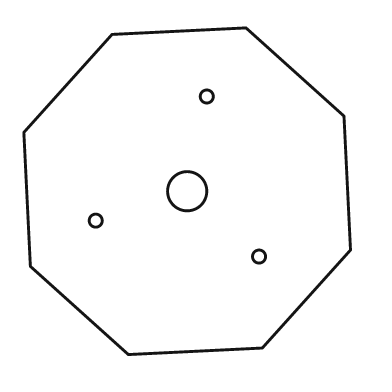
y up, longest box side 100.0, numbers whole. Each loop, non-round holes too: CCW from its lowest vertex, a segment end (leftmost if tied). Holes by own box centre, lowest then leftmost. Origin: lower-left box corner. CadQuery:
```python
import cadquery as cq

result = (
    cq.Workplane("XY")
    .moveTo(32.0, 0.0)
    .lineTo(73.0, 2.0)
    .lineTo(100.0, 32.0)
    .lineTo(98.0, 73.0)
    .lineTo(68.0, 100.0)
    .lineTo(27.0, 98.0)
    .lineTo(0.0, 68.0)
    .lineTo(2.0, 27.0)
    .close()
    .moveTo(72.0, 30.0)
    .circle(2.0)
    .moveTo(22.0, 41.0)
    .circle(2.0)
    .moveTo(50.0, 50.0)
    .circle(6.0)
    .moveTo(56.0, 79.0)
    .circle(2.0)
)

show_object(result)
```